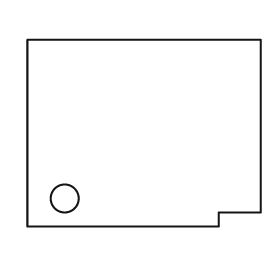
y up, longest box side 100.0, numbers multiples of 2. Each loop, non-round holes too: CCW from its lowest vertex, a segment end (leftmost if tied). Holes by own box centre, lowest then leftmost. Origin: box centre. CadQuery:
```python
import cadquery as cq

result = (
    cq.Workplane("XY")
    .moveTo(-50.0, -40.0)
    .lineTo(32.0, -40.0)
    .lineTo(32.0, -34.0)
    .lineTo(50.0, -34.0)
    .lineTo(50.0, 40.0)
    .lineTo(-50.0, 40.0)
    .close()
    .moveTo(-34.0, -28.0)
    .circle(6.0)
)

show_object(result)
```